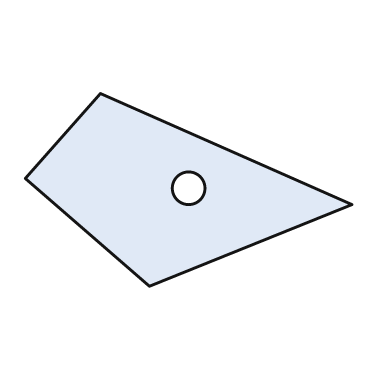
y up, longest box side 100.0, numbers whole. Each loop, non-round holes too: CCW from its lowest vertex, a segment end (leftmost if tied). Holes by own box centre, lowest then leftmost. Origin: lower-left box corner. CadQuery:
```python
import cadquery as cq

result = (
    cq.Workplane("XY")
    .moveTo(38.0, 0.0)
    .lineTo(100.0, 25.0)
    .lineTo(23.0, 59.0)
    .lineTo(0.0, 33.0)
    .close()
    .moveTo(50.0, 30.0)
    .circle(5.0)
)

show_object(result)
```